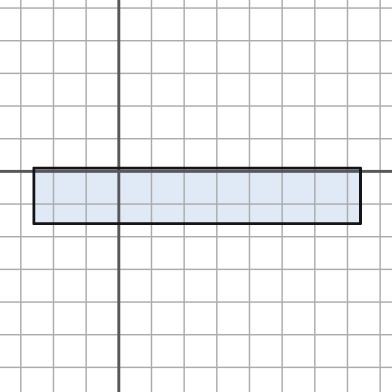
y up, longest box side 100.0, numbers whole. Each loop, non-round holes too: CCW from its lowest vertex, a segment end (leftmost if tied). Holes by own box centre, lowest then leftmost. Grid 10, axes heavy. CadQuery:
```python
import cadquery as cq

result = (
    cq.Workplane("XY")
    .moveTo(-26.0, -16.0)
    .lineTo(74.0, -16.0)
    .lineTo(74.0, 1.0)
    .lineTo(-26.0, 1.0)
    .close()
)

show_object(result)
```